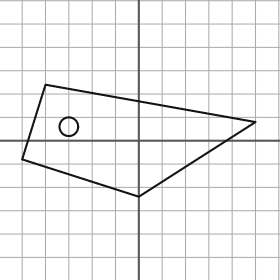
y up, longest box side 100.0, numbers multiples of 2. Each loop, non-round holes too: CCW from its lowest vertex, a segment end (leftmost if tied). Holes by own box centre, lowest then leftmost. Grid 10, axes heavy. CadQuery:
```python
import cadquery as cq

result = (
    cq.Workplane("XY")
    .moveTo(0.0, -24.0)
    .lineTo(50.0, 8.0)
    .lineTo(-40.0, 24.0)
    .lineTo(-50.0, -8.0)
    .close()
    .moveTo(-30.0, 6.0)
    .circle(4.0)
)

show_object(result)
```